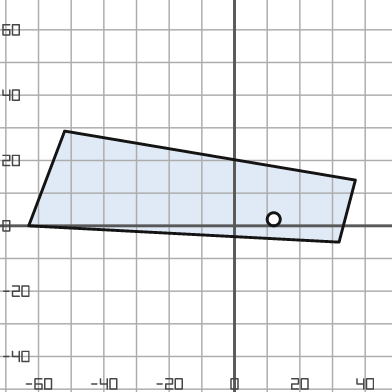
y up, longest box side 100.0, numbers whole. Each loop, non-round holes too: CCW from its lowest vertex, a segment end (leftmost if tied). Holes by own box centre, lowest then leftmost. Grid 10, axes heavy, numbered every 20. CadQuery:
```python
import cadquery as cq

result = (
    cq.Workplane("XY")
    .moveTo(32.0, -5.0)
    .lineTo(37.0, 14.0)
    .lineTo(-52.0, 29.0)
    .lineTo(-63.0, 0.0)
    .close()
    .moveTo(12.0, 2.0)
    .circle(2.0)
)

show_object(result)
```